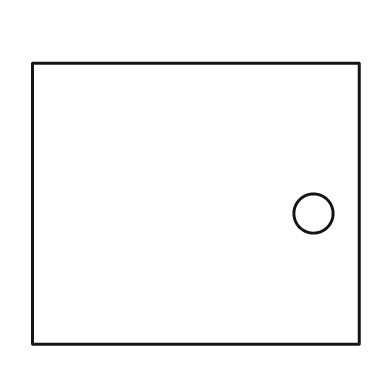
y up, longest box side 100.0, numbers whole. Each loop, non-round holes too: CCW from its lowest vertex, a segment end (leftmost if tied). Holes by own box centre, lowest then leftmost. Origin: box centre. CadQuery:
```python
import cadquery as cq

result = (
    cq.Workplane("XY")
    .moveTo(-50.0, -43.0)
    .lineTo(50.0, -43.0)
    .lineTo(50.0, 43.0)
    .lineTo(-50.0, 43.0)
    .close()
    .moveTo(36.0, -3.0)
    .circle(6.0)
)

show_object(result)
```